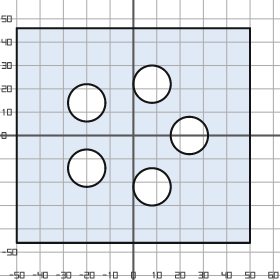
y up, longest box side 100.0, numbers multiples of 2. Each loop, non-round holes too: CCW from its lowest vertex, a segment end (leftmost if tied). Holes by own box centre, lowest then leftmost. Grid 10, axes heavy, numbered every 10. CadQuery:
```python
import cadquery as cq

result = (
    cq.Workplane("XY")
    .moveTo(-50.0, -46.0)
    .lineTo(50.0, -46.0)
    .lineTo(50.0, 46.0)
    .lineTo(-50.0, 46.0)
    .close()
    .moveTo(8.0, -22.0)
    .circle(8.0)
    .moveTo(-20.0, -14.0)
    .circle(8.0)
    .moveTo(24.0, 0.0)
    .circle(8.0)
    .moveTo(-20.0, 14.0)
    .circle(8.0)
    .moveTo(8.0, 22.0)
    .circle(8.0)
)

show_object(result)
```